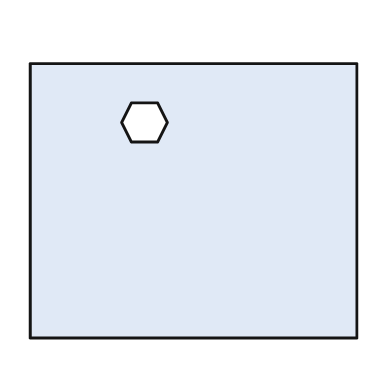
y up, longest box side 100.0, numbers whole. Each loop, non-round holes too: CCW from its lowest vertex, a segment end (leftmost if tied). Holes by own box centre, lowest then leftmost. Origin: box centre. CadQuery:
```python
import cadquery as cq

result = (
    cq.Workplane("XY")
    .moveTo(-50.0, -42.0)
    .lineTo(50.0, -42.0)
    .lineTo(50.0, 42.0)
    .lineTo(-50.0, 42.0)
    .close()
    .moveTo(-19.0, 18.0)
    .lineTo(-11.0, 18.0)
    .lineTo(-8.0, 24.0)
    .lineTo(-11.0, 30.0)
    .lineTo(-19.0, 30.0)
    .lineTo(-22.0, 24.0)
    .close()
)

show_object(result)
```